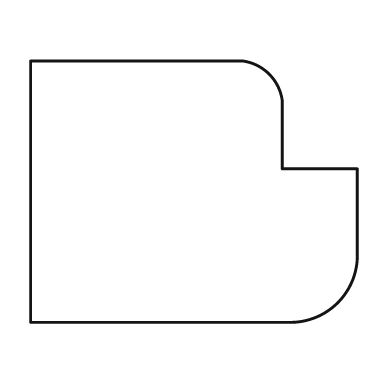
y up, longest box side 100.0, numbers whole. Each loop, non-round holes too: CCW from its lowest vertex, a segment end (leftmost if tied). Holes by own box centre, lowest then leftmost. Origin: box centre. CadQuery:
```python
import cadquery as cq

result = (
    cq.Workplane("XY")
    .moveTo(-50.0, -40.0)
    .lineTo(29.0, -40.0)
    .threePointArc((44.0, -34.0), (50.0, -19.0))
    .lineTo(50.0, 7.0)
    .lineTo(27.0, 7.0)
    .lineTo(27.0, 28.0)
    .threePointArc((23.0, 36.0), (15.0, 40.0))
    .lineTo(-50.0, 40.0)
    .close()
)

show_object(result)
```